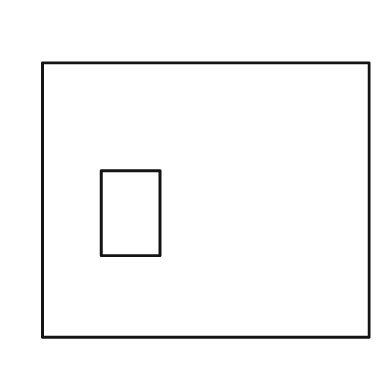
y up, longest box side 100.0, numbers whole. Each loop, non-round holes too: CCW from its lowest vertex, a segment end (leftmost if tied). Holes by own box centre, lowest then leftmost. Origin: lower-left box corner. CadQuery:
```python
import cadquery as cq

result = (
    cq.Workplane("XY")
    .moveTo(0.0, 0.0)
    .lineTo(100.0, 0.0)
    .lineTo(100.0, 84.0)
    .lineTo(0.0, 84.0)
    .close()
    .moveTo(18.0, 25.0)
    .lineTo(36.0, 25.0)
    .lineTo(36.0, 51.0)
    .lineTo(18.0, 51.0)
    .close()
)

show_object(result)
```